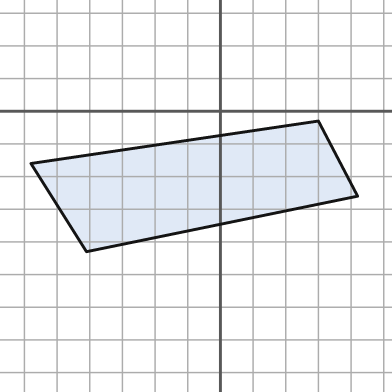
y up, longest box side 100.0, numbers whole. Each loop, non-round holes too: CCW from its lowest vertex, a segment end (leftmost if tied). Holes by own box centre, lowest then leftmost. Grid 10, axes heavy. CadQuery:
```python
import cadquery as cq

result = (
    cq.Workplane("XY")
    .moveTo(-41.0, -43.0)
    .lineTo(42.0, -26.0)
    .lineTo(30.0, -3.0)
    .lineTo(-58.0, -16.0)
    .close()
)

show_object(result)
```